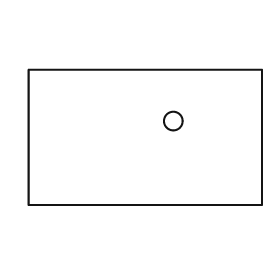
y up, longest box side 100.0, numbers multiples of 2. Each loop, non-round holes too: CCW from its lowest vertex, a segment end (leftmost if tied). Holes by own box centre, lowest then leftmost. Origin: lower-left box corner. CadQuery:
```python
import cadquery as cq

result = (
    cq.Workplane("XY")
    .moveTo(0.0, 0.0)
    .lineTo(100.0, 0.0)
    .lineTo(100.0, 58.0)
    .lineTo(0.0, 58.0)
    .close()
    .moveTo(62.0, 36.0)
    .circle(4.0)
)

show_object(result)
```